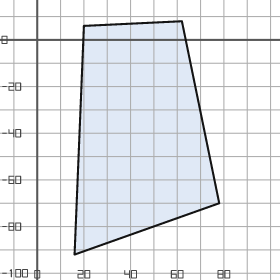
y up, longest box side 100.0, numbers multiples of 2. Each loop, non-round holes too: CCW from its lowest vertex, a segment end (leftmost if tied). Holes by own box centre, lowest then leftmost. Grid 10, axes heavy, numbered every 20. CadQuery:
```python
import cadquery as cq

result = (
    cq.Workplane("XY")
    .moveTo(16.0, -92.0)
    .lineTo(78.0, -70.0)
    .lineTo(62.0, 8.0)
    .lineTo(20.0, 6.0)
    .close()
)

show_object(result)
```